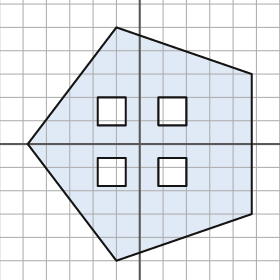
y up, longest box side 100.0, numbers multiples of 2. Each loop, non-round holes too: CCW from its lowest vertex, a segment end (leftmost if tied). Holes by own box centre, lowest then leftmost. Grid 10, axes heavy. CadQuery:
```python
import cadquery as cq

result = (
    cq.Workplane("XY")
    .moveTo(-10.0, -50.0)
    .lineTo(48.0, -30.0)
    .lineTo(48.0, 30.0)
    .lineTo(-10.0, 50.0)
    .lineTo(-48.0, 0.0)
    .close()
    .moveTo(-18.0, -18.0)
    .lineTo(-6.0, -18.0)
    .lineTo(-6.0, -6.0)
    .lineTo(-18.0, -6.0)
    .close()
    .moveTo(8.0, -18.0)
    .lineTo(20.0, -18.0)
    .lineTo(20.0, -6.0)
    .lineTo(8.0, -6.0)
    .close()
    .moveTo(-18.0, 8.0)
    .lineTo(-6.0, 8.0)
    .lineTo(-6.0, 20.0)
    .lineTo(-18.0, 20.0)
    .close()
    .moveTo(8.0, 8.0)
    .lineTo(20.0, 8.0)
    .lineTo(20.0, 20.0)
    .lineTo(8.0, 20.0)
    .close()
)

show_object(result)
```